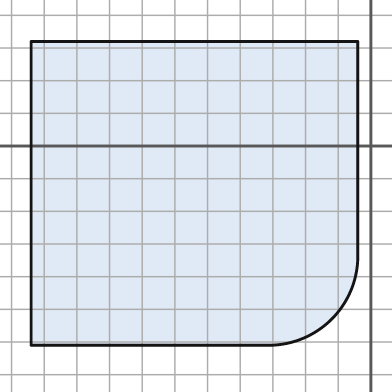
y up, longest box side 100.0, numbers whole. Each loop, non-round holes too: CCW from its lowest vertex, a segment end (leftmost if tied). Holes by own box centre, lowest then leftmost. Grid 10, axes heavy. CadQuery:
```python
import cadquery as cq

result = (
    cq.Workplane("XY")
    .moveTo(-104.0, -61.0)
    .lineTo(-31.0, -61.0)
    .threePointArc((-12.0, -53.0), (-4.0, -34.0))
    .lineTo(-4.0, 32.0)
    .lineTo(-104.0, 32.0)
    .close()
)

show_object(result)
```